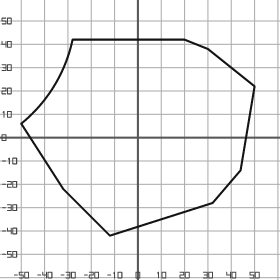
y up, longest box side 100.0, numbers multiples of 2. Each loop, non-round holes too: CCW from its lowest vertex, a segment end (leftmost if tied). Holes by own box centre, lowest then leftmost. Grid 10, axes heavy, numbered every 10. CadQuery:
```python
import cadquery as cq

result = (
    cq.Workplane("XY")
    .moveTo(-12.0, -42.0)
    .lineTo(32.0, -28.0)
    .lineTo(44.0, -14.0)
    .lineTo(50.0, 22.0)
    .lineTo(30.0, 38.0)
    .lineTo(20.0, 42.0)
    .lineTo(-28.0, 42.0)
    .threePointArc((-36.0, 22.0), (-50.0, 6.0))
    .lineTo(-32.0, -22.0)
    .close()
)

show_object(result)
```